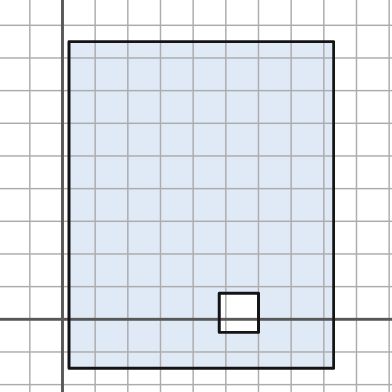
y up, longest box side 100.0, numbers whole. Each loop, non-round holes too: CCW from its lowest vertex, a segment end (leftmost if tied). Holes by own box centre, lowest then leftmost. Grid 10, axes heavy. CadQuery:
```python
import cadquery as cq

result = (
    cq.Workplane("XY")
    .moveTo(2.0, -15.0)
    .lineTo(83.0, -15.0)
    .lineTo(83.0, 85.0)
    .lineTo(2.0, 85.0)
    .close()
    .moveTo(48.0, -4.0)
    .lineTo(60.0, -4.0)
    .lineTo(60.0, 8.0)
    .lineTo(48.0, 8.0)
    .close()
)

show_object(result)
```